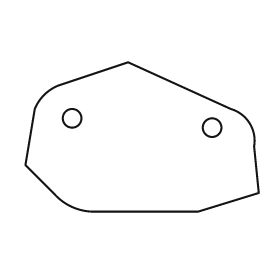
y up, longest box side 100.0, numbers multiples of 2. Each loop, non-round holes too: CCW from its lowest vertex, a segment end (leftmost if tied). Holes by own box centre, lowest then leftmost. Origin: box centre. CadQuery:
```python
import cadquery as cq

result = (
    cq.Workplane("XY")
    .moveTo(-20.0, -32.0)
    .lineTo(24.0, -32.0)
    .lineTo(50.0, -24.0)
    .lineTo(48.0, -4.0)
    .threePointArc((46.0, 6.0), (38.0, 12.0))
    .lineTo(-6.0, 32.0)
    .lineTo(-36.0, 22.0)
    .threePointArc((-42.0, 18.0), (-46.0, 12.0))
    .lineTo(-50.0, -12.0)
    .lineTo(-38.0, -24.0)
    .threePointArc((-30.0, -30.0), (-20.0, -32.0))
    .close()
    .moveTo(30.0, 4.0)
    .circle(4.0)
    .moveTo(-30.0, 8.0)
    .circle(4.0)
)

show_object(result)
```